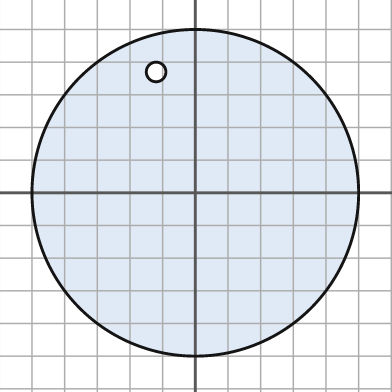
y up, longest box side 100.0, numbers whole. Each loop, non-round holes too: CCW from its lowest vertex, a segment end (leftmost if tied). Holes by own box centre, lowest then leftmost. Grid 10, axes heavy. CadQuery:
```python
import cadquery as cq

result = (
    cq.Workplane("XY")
    .moveTo(0.0, 0.0)
    .circle(50.0)
    .moveTo(-12.0, 37.0)
    .circle(3.0)
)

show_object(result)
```